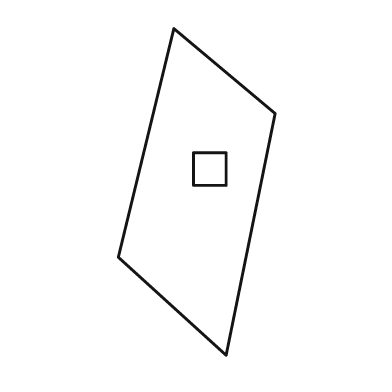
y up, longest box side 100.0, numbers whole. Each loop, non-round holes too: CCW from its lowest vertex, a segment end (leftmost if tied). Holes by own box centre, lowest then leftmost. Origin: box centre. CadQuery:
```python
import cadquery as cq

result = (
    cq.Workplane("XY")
    .moveTo(9.0, -50.0)
    .lineTo(24.0, 24.0)
    .lineTo(-7.0, 50.0)
    .lineTo(-24.0, -20.0)
    .close()
    .moveTo(-1.0, 2.0)
    .lineTo(9.0, 2.0)
    .lineTo(9.0, 12.0)
    .lineTo(-1.0, 12.0)
    .close()
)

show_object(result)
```